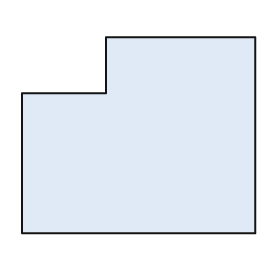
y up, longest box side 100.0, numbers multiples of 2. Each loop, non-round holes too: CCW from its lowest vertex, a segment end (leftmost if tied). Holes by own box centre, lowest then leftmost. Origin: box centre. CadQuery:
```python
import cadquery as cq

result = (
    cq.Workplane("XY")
    .moveTo(-50.0, -42.0)
    .lineTo(50.0, -42.0)
    .lineTo(50.0, 42.0)
    .lineTo(-14.0, 42.0)
    .lineTo(-14.0, 18.0)
    .lineTo(-50.0, 18.0)
    .close()
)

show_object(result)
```